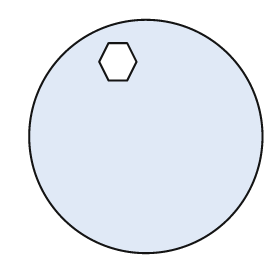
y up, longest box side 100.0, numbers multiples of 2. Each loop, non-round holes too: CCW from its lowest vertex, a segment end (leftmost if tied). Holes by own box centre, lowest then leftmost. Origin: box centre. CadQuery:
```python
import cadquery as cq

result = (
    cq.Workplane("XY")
    .moveTo(0.0, 0.0)
    .circle(50.0)
    .moveTo(-16.0, 24.0)
    .lineTo(-8.0, 24.0)
    .lineTo(-4.0, 32.0)
    .lineTo(-8.0, 40.0)
    .lineTo(-16.0, 40.0)
    .lineTo(-20.0, 32.0)
    .close()
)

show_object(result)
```